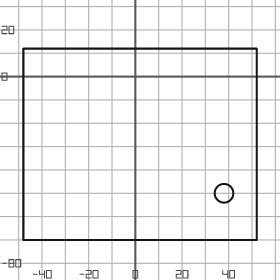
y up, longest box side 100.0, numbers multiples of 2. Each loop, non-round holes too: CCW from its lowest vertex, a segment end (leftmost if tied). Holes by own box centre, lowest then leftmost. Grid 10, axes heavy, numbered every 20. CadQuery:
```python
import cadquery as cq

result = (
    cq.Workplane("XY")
    .moveTo(-48.0, -70.0)
    .lineTo(52.0, -70.0)
    .lineTo(52.0, 12.0)
    .lineTo(-48.0, 12.0)
    .close()
    .moveTo(38.0, -50.0)
    .circle(4.0)
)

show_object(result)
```